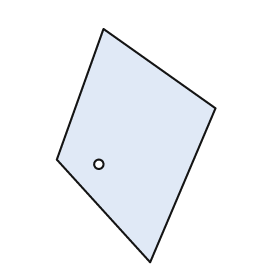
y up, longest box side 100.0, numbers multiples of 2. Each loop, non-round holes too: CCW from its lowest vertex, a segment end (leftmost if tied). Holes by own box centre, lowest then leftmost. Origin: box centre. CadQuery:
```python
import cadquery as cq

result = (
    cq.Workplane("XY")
    .moveTo(6.0, -50.0)
    .lineTo(34.0, 16.0)
    .lineTo(-14.0, 50.0)
    .lineTo(-34.0, -6.0)
    .close()
    .moveTo(-16.0, -8.0)
    .circle(2.0)
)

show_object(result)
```